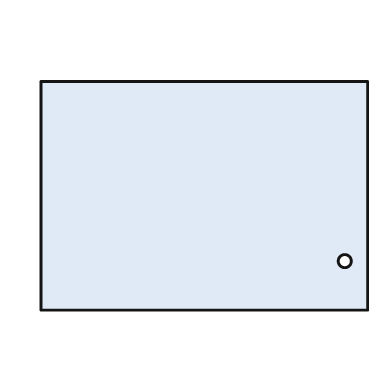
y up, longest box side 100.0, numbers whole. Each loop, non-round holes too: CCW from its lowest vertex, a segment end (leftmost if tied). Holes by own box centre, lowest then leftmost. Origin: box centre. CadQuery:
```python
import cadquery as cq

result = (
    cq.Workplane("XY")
    .moveTo(-50.0, -35.0)
    .lineTo(50.0, -35.0)
    .lineTo(50.0, 35.0)
    .lineTo(-50.0, 35.0)
    .close()
    .moveTo(43.0, -20.0)
    .circle(2.0)
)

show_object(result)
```